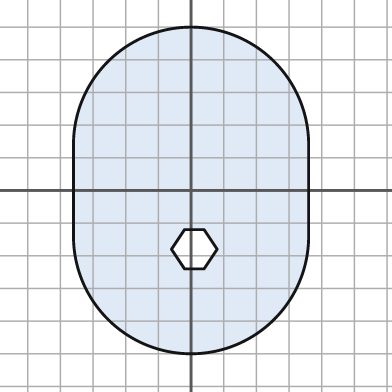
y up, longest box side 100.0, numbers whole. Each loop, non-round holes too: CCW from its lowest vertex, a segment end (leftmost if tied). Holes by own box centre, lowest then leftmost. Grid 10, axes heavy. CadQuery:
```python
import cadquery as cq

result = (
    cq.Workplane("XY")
    .moveTo(-36.0, -14.0)
    .threePointArc((0.0, -50.0), (36.0, -14.0))
    .lineTo(36.0, 14.0)
    .threePointArc((0.0, 50.0), (-36.0, 14.0))
    .close()
    .moveTo(-2.0, -24.0)
    .lineTo(4.0, -24.0)
    .lineTo(8.0, -18.0)
    .lineTo(4.0, -12.0)
    .lineTo(-2.0, -12.0)
    .lineTo(-6.0, -18.0)
    .close()
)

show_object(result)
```